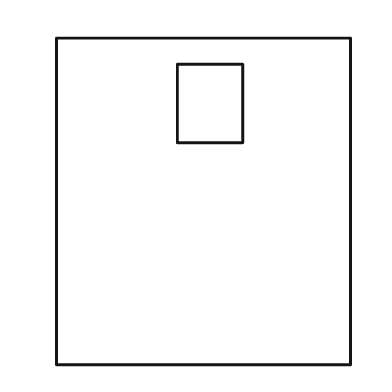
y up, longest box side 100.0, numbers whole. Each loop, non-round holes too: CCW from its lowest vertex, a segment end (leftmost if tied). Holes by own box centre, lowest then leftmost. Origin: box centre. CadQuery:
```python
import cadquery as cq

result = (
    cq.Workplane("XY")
    .moveTo(-45.0, -50.0)
    .lineTo(45.0, -50.0)
    .lineTo(45.0, 50.0)
    .lineTo(-45.0, 50.0)
    .close()
    .moveTo(-8.0, 18.0)
    .lineTo(12.0, 18.0)
    .lineTo(12.0, 42.0)
    .lineTo(-8.0, 42.0)
    .close()
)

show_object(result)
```